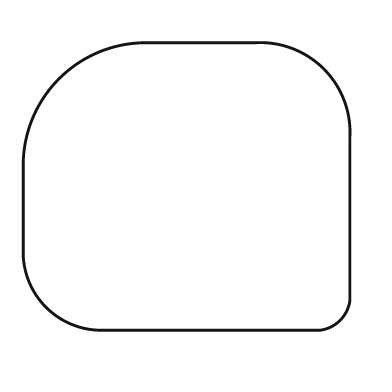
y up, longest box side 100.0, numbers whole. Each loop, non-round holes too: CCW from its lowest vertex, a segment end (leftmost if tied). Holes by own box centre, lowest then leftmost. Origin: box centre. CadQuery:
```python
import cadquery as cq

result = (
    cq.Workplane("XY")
    .moveTo(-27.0, -44.0)
    .lineTo(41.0, -44.0)
    .threePointArc((47.0, -41.0), (50.0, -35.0))
    .lineTo(50.0, 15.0)
    .threePointArc((42.0, 36.0), (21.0, 44.0))
    .lineTo(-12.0, 44.0)
    .threePointArc((-39.0, 33.0), (-50.0, 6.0))
    .lineTo(-50.0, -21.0)
    .threePointArc((-43.0, -37.0), (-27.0, -44.0))
    .close()
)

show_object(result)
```